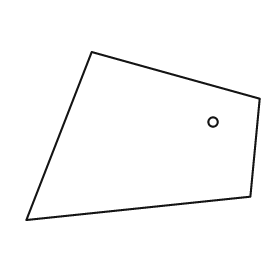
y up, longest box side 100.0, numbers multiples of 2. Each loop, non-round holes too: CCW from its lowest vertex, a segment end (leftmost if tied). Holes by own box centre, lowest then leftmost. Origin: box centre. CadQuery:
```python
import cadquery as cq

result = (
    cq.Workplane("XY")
    .moveTo(-50.0, -36.0)
    .lineTo(46.0, -26.0)
    .lineTo(50.0, 16.0)
    .lineTo(-22.0, 36.0)
    .close()
    .moveTo(30.0, 6.0)
    .circle(2.0)
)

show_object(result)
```